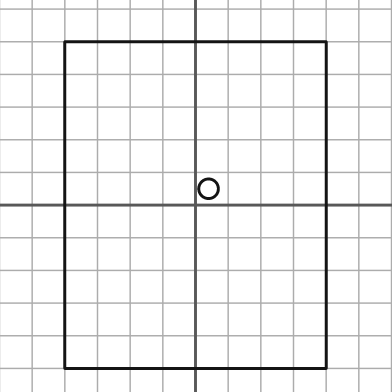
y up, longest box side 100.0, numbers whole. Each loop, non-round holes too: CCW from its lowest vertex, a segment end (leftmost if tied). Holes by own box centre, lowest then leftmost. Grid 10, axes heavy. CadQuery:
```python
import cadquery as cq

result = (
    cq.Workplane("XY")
    .moveTo(-40.0, -50.0)
    .lineTo(40.0, -50.0)
    .lineTo(40.0, 50.0)
    .lineTo(-40.0, 50.0)
    .close()
    .moveTo(4.0, 5.0)
    .circle(3.0)
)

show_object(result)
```